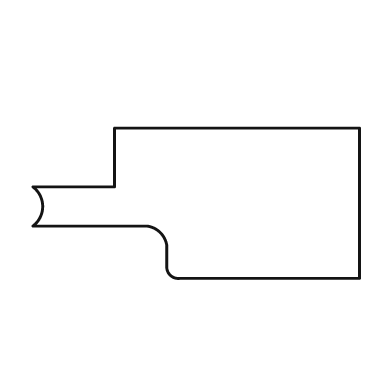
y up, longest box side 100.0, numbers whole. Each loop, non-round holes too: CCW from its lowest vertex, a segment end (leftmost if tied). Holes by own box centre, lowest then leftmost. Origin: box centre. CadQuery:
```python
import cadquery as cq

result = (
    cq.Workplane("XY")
    .moveTo(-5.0, -23.0)
    .lineTo(50.0, -23.0)
    .lineTo(50.0, 23.0)
    .lineTo(-25.0, 23.0)
    .lineTo(-25.0, 5.0)
    .lineTo(-50.0, 5.0)
    .threePointArc((-47.0, -1.0), (-50.0, -7.0))
    .lineTo(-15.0, -7.0)
    .threePointArc((-11.0, -9.0), (-9.0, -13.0))
    .lineTo(-9.0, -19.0)
    .threePointArc((-8.0, -22.0), (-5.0, -23.0))
    .close()
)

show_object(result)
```